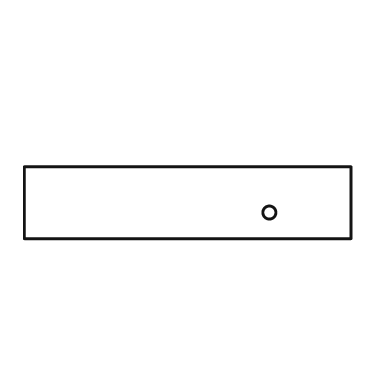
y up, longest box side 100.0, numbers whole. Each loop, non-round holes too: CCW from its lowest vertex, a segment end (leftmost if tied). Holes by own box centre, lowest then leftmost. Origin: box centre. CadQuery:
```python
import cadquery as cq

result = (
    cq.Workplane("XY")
    .moveTo(-50.0, -11.0)
    .lineTo(50.0, -11.0)
    .lineTo(50.0, 11.0)
    .lineTo(-50.0, 11.0)
    .close()
    .moveTo(25.0, -3.0)
    .circle(2.0)
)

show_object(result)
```